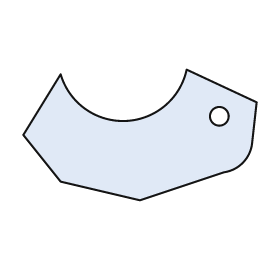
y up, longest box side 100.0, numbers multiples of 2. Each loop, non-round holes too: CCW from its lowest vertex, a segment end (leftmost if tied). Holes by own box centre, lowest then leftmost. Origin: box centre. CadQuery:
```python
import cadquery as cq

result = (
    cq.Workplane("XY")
    .moveTo(0.0, -28.0)
    .lineTo(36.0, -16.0)
    .threePointArc((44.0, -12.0), (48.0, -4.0))
    .lineTo(50.0, 14.0)
    .lineTo(20.0, 28.0)
    .threePointArc((-6.0, 6.0), (-34.0, 26.0))
    .lineTo(-50.0, 0.0)
    .lineTo(-34.0, -20.0)
    .close()
    .moveTo(34.0, 8.0)
    .circle(4.0)
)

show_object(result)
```